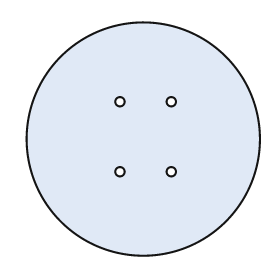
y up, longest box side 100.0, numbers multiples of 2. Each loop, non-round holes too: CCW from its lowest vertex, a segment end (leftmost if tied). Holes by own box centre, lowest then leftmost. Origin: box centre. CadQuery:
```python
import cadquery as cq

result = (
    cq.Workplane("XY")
    .moveTo(0.0, 0.0)
    .circle(50.0)
    .moveTo(-10.0, -14.0)
    .circle(2.0)
    .moveTo(12.0, -14.0)
    .circle(2.0)
    .moveTo(-10.0, 16.0)
    .circle(2.0)
    .moveTo(12.0, 16.0)
    .circle(2.0)
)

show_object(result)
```